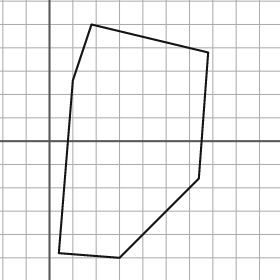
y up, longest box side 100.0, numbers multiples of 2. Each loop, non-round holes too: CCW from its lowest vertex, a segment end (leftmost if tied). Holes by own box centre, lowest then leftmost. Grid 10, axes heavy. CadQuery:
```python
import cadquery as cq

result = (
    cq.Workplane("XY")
    .moveTo(30.0, -50.0)
    .lineTo(64.0, -16.0)
    .lineTo(68.0, 38.0)
    .lineTo(18.0, 50.0)
    .lineTo(10.0, 26.0)
    .lineTo(4.0, -48.0)
    .close()
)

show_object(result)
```